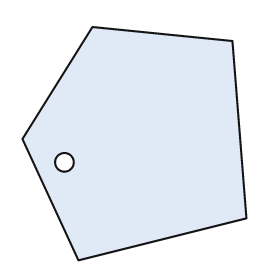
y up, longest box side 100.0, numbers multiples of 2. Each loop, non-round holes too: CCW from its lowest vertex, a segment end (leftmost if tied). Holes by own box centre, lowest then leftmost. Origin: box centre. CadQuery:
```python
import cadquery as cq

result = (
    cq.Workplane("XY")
    .moveTo(-24.0, -50.0)
    .lineTo(48.0, -32.0)
    .lineTo(42.0, 44.0)
    .lineTo(-18.0, 50.0)
    .lineTo(-48.0, 2.0)
    .close()
    .moveTo(-30.0, -8.0)
    .circle(4.0)
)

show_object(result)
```